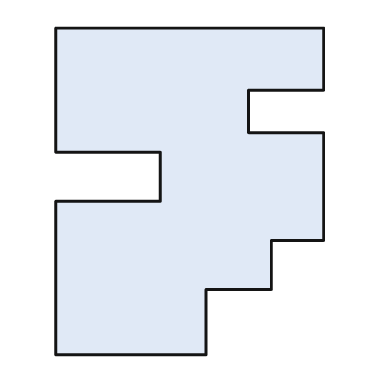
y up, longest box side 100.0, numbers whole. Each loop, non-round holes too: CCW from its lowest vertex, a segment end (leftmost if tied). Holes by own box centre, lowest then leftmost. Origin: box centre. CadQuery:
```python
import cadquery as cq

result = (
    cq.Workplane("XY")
    .moveTo(-41.0, -50.0)
    .lineTo(5.0, -50.0)
    .lineTo(5.0, -30.0)
    .lineTo(25.0, -30.0)
    .lineTo(25.0, -15.0)
    .lineTo(41.0, -15.0)
    .lineTo(41.0, 18.0)
    .lineTo(18.0, 18.0)
    .lineTo(18.0, 31.0)
    .lineTo(41.0, 31.0)
    .lineTo(41.0, 50.0)
    .lineTo(-41.0, 50.0)
    .lineTo(-41.0, 12.0)
    .lineTo(-9.0, 12.0)
    .lineTo(-9.0, -3.0)
    .lineTo(-41.0, -3.0)
    .close()
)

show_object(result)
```